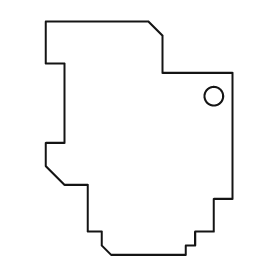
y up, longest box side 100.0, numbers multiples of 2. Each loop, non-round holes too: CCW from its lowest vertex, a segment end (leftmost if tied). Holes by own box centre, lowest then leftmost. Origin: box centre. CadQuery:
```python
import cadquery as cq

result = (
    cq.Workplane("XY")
    .moveTo(-12.0, -50.0)
    .lineTo(20.0, -50.0)
    .lineTo(20.0, -46.0)
    .lineTo(24.0, -46.0)
    .lineTo(24.0, -40.0)
    .lineTo(32.0, -40.0)
    .lineTo(32.0, -26.0)
    .lineTo(40.0, -26.0)
    .lineTo(40.0, 28.0)
    .lineTo(10.0, 28.0)
    .lineTo(10.0, 44.0)
    .lineTo(4.0, 50.0)
    .lineTo(-40.0, 50.0)
    .lineTo(-40.0, 32.0)
    .lineTo(-32.0, 32.0)
    .lineTo(-32.0, -2.0)
    .lineTo(-40.0, -2.0)
    .lineTo(-40.0, -12.0)
    .lineTo(-32.0, -20.0)
    .lineTo(-22.0, -20.0)
    .lineTo(-22.0, -40.0)
    .lineTo(-16.0, -40.0)
    .lineTo(-16.0, -46.0)
    .close()
    .moveTo(32.0, 18.0)
    .circle(4.0)
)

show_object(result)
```